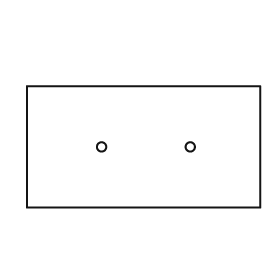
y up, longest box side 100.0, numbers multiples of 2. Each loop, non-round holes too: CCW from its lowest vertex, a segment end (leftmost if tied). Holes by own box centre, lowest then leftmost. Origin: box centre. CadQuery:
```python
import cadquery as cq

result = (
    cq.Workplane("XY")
    .moveTo(-50.0, -26.0)
    .lineTo(50.0, -26.0)
    .lineTo(50.0, 26.0)
    .lineTo(-50.0, 26.0)
    .close()
    .moveTo(-18.0, 0.0)
    .circle(2.0)
    .moveTo(20.0, 0.0)
    .circle(2.0)
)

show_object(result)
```